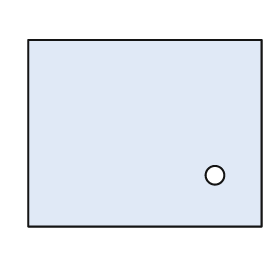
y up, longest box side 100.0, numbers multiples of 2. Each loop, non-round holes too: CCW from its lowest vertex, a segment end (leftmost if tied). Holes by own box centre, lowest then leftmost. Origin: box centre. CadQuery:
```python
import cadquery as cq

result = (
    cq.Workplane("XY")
    .moveTo(-50.0, -40.0)
    .lineTo(50.0, -40.0)
    .lineTo(50.0, 40.0)
    .lineTo(-50.0, 40.0)
    .close()
    .moveTo(30.0, -18.0)
    .circle(4.0)
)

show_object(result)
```